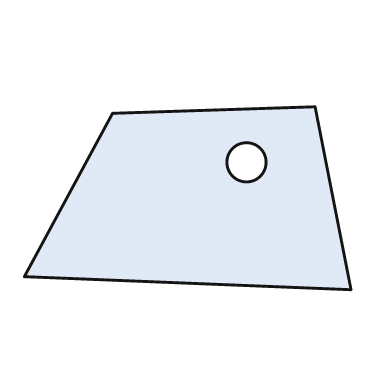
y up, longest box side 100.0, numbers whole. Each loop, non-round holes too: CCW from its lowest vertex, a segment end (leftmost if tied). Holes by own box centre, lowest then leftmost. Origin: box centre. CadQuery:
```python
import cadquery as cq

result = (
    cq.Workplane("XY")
    .moveTo(50.0, -28.0)
    .lineTo(39.0, 28.0)
    .lineTo(-23.0, 26.0)
    .lineTo(-50.0, -24.0)
    .close()
    .moveTo(18.0, 11.0)
    .circle(6.0)
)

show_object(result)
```